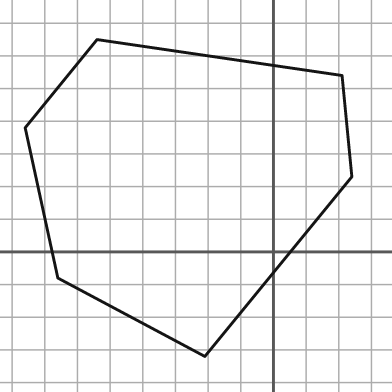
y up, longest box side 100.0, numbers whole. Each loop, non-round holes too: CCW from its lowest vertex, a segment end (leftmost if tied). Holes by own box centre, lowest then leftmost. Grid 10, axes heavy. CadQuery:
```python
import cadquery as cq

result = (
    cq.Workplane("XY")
    .moveTo(-21.0, -32.0)
    .lineTo(24.0, 23.0)
    .lineTo(21.0, 54.0)
    .lineTo(-54.0, 65.0)
    .lineTo(-76.0, 38.0)
    .lineTo(-66.0, -8.0)
    .close()
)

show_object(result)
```